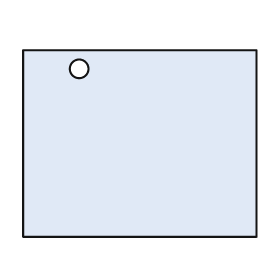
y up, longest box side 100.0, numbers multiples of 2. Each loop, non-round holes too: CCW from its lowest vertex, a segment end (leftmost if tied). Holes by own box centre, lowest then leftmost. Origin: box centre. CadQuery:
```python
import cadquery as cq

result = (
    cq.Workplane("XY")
    .moveTo(-50.0, -40.0)
    .lineTo(50.0, -40.0)
    .lineTo(50.0, 40.0)
    .lineTo(-50.0, 40.0)
    .close()
    .moveTo(-26.0, 32.0)
    .circle(4.0)
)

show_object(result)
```